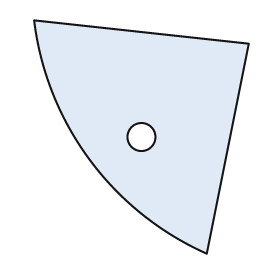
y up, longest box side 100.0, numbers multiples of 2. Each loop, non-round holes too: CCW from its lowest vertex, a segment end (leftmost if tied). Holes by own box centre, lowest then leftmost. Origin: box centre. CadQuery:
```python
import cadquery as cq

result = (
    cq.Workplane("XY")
    .moveTo(28.0, -50.0)
    .lineTo(46.0, 40.0)
    .lineTo(-46.0, 50.0)
    .threePointArc((-22.0, -10.0), (28.0, -50.0))
    .close()
    .moveTo(0.0, 0.0)
    .circle(6.0)
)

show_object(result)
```